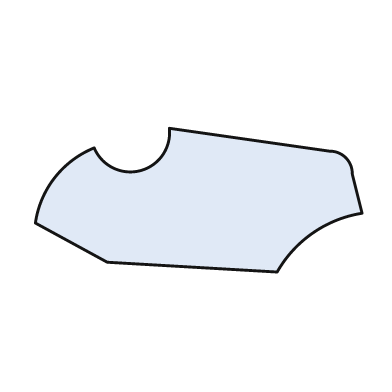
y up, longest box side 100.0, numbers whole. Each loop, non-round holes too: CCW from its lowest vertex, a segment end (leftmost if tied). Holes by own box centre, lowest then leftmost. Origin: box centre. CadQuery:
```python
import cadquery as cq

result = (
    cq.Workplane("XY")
    .moveTo(24.0, -22.0)
    .threePointArc((35.0, -10.0), (50.0, -4.0))
    .lineTo(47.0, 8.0)
    .threePointArc((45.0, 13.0), (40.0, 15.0))
    .lineTo(-9.0, 22.0)
    .threePointArc((-18.0, 9.0), (-32.0, 16.0))
    .threePointArc((-44.0, 7.0), (-50.0, -7.0))
    .lineTo(-28.0, -19.0)
    .close()
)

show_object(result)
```